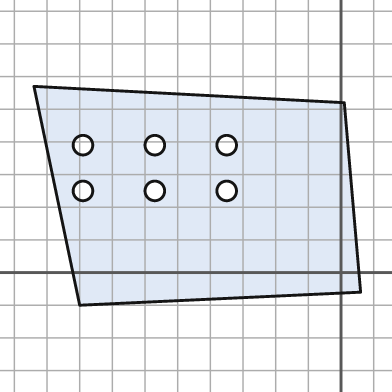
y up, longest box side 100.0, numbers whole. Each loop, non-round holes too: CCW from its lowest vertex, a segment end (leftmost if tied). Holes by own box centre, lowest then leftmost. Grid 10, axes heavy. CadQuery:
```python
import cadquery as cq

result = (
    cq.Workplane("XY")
    .moveTo(-80.0, -10.0)
    .lineTo(6.0, -6.0)
    .lineTo(1.0, 52.0)
    .lineTo(-94.0, 57.0)
    .close()
    .moveTo(-79.0, 25.0)
    .circle(3.0)
    .moveTo(-57.0, 25.0)
    .circle(3.0)
    .moveTo(-35.0, 25.0)
    .circle(3.0)
    .moveTo(-79.0, 39.0)
    .circle(3.0)
    .moveTo(-57.0, 39.0)
    .circle(3.0)
    .moveTo(-35.0, 39.0)
    .circle(3.0)
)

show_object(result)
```